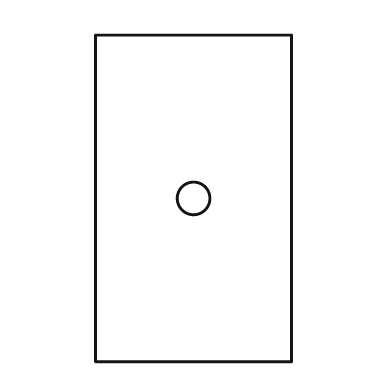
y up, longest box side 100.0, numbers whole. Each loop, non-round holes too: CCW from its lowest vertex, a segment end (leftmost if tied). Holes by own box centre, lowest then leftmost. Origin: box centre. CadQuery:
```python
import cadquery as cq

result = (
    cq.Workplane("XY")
    .moveTo(-30.0, -50.0)
    .lineTo(30.0, -50.0)
    .lineTo(30.0, 50.0)
    .lineTo(-30.0, 50.0)
    .close()
    .moveTo(0.0, 0.0)
    .circle(5.0)
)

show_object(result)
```